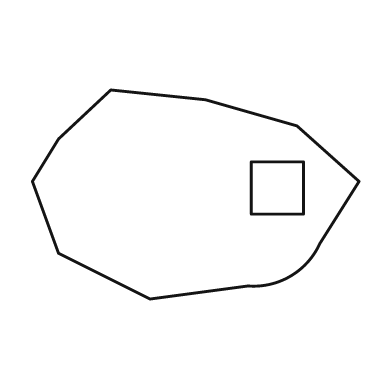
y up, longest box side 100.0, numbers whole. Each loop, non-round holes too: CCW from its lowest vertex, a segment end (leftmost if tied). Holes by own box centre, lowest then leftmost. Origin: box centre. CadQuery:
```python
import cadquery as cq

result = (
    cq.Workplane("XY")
    .moveTo(-14.0, -32.0)
    .lineTo(16.0, -28.0)
    .threePointArc((29.0, -25.0), (38.0, -15.0))
    .lineTo(50.0, 4.0)
    .lineTo(31.0, 21.0)
    .lineTo(3.0, 29.0)
    .lineTo(-26.0, 32.0)
    .lineTo(-42.0, 17.0)
    .lineTo(-50.0, 4.0)
    .lineTo(-42.0, -18.0)
    .close()
    .moveTo(17.0, -6.0)
    .lineTo(33.0, -6.0)
    .lineTo(33.0, 10.0)
    .lineTo(17.0, 10.0)
    .close()
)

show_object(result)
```